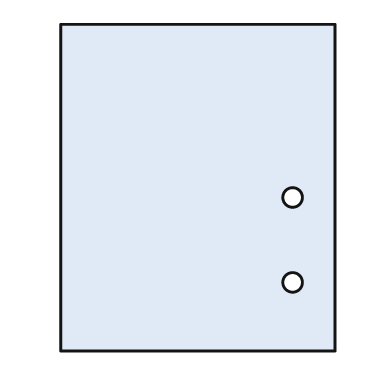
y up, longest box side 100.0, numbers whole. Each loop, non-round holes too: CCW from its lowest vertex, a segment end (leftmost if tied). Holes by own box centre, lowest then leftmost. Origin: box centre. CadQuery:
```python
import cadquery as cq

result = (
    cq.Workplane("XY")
    .moveTo(-42.0, -50.0)
    .lineTo(42.0, -50.0)
    .lineTo(42.0, 50.0)
    .lineTo(-42.0, 50.0)
    .close()
    .moveTo(29.0, -29.0)
    .circle(3.0)
    .moveTo(29.0, -3.0)
    .circle(3.0)
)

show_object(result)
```